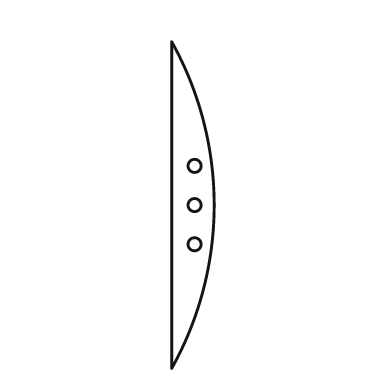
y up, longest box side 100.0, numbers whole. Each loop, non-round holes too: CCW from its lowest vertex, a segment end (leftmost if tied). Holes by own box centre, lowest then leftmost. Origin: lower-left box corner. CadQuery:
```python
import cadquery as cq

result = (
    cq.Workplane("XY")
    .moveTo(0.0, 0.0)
    .threePointArc((13.0, 50.0), (0.0, 100.0))
    .close()
    .moveTo(7.0, 38.0)
    .circle(2.0)
    .moveTo(7.0, 50.0)
    .circle(2.0)
    .moveTo(7.0, 62.0)
    .circle(2.0)
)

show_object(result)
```